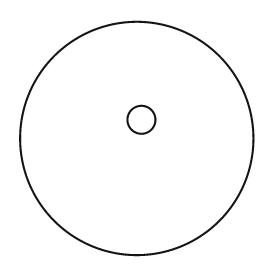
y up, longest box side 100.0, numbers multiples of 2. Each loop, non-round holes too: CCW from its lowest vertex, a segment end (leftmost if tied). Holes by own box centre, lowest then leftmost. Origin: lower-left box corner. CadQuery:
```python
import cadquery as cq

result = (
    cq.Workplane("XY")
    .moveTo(50.0, 50.0)
    .circle(50.0)
    .moveTo(52.0, 58.0)
    .circle(6.0)
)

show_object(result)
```